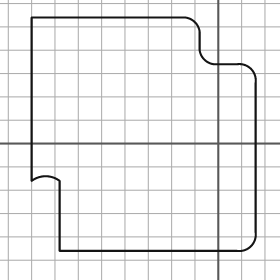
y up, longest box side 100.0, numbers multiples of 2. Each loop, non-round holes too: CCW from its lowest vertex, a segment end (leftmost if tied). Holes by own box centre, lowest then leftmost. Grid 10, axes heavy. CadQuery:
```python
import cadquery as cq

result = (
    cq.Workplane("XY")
    .moveTo(-68.0, -46.0)
    .lineTo(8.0, -46.0)
    .threePointArc((14.0, -44.0), (16.0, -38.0))
    .lineTo(16.0, 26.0)
    .threePointArc((14.0, 32.0), (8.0, 34.0))
    .lineTo(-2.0, 34.0)
    .threePointArc((-6.0, 36.0), (-8.0, 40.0))
    .lineTo(-8.0, 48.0)
    .threePointArc((-10.0, 52.0), (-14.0, 54.0))
    .lineTo(-80.0, 54.0)
    .lineTo(-80.0, -16.0)
    .threePointArc((-74.0, -14.0), (-68.0, -16.0))
    .close()
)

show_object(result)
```